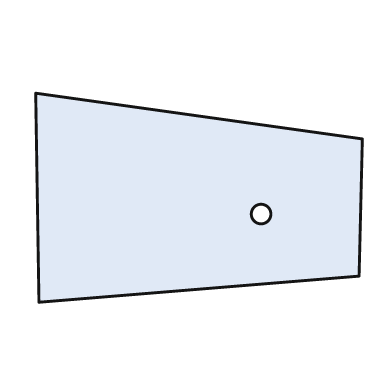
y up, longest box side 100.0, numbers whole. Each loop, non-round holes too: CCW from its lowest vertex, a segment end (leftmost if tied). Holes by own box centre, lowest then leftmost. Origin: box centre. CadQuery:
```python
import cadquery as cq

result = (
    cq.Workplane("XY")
    .moveTo(-49.0, -32.0)
    .lineTo(49.0, -24.0)
    .lineTo(50.0, 18.0)
    .lineTo(-50.0, 32.0)
    .close()
    .moveTo(19.0, -5.0)
    .circle(3.0)
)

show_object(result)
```